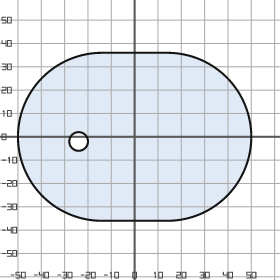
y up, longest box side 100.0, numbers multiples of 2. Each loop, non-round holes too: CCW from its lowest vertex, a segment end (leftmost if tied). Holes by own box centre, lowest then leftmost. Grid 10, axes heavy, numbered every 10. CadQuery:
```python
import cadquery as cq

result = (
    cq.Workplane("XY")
    .moveTo(-14.0, -36.0)
    .lineTo(14.0, -36.0)
    .threePointArc((50.0, 0.0), (14.0, 36.0))
    .lineTo(-14.0, 36.0)
    .threePointArc((-50.0, 0.0), (-14.0, -36.0))
    .close()
    .moveTo(-24.0, -2.0)
    .circle(4.0)
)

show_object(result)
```